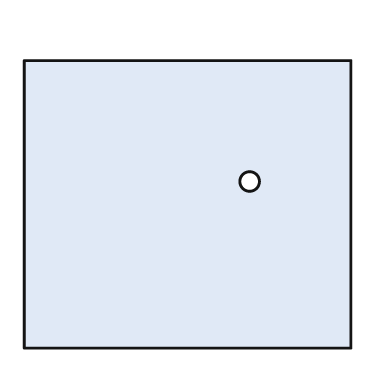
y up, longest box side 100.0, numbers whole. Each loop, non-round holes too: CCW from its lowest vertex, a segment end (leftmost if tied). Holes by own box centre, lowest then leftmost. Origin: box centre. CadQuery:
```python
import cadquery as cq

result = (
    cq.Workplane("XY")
    .moveTo(-50.0, -44.0)
    .lineTo(50.0, -44.0)
    .lineTo(50.0, 44.0)
    .lineTo(-50.0, 44.0)
    .close()
    .moveTo(19.0, 7.0)
    .circle(3.0)
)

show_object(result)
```